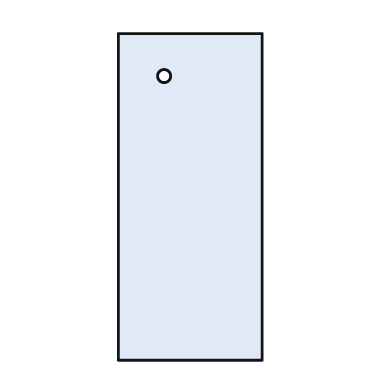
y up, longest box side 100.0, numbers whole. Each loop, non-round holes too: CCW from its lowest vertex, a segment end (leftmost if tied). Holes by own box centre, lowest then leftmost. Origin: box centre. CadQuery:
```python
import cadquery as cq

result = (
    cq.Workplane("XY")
    .moveTo(-22.0, -50.0)
    .lineTo(22.0, -50.0)
    .lineTo(22.0, 50.0)
    .lineTo(-22.0, 50.0)
    .close()
    .moveTo(-8.0, 37.0)
    .circle(2.0)
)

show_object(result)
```